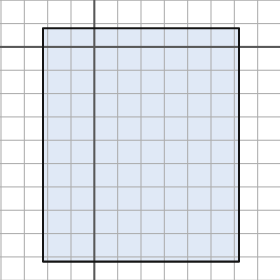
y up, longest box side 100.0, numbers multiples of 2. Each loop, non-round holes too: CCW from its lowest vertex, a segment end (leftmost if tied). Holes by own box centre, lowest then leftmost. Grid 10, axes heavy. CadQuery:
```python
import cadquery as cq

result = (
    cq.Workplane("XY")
    .moveTo(-22.0, -92.0)
    .lineTo(62.0, -92.0)
    .lineTo(62.0, 8.0)
    .lineTo(-22.0, 8.0)
    .close()
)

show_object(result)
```